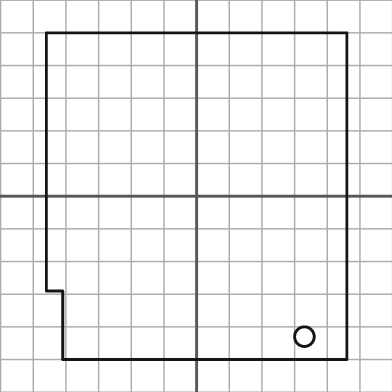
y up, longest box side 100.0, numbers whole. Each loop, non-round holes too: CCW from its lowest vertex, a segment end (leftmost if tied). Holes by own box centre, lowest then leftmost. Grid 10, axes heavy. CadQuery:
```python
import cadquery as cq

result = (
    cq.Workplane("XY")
    .moveTo(-41.0, -50.0)
    .lineTo(46.0, -50.0)
    .lineTo(46.0, 50.0)
    .lineTo(-46.0, 50.0)
    .lineTo(-46.0, -29.0)
    .lineTo(-41.0, -29.0)
    .close()
    .moveTo(33.0, -43.0)
    .circle(3.0)
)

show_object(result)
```